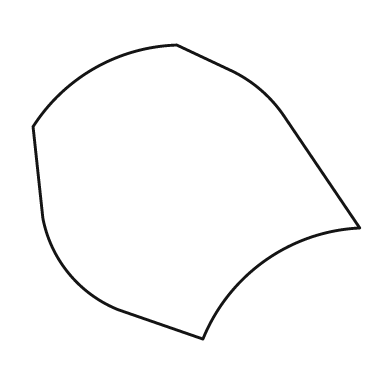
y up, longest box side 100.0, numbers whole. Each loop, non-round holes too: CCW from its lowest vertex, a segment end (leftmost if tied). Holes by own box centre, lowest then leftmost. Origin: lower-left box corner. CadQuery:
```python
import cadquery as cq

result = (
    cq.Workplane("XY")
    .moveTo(52.0, 0.0)
    .threePointArc((71.0, 24.0), (100.0, 34.0))
    .lineTo(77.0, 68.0)
    .threePointArc((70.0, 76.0), (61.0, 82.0))
    .lineTo(44.0, 90.0)
    .threePointArc((19.0, 83.0), (0.0, 65.0))
    .lineTo(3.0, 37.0)
    .threePointArc((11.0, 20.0), (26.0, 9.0))
    .close()
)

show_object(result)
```